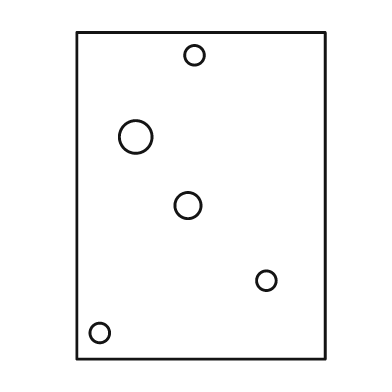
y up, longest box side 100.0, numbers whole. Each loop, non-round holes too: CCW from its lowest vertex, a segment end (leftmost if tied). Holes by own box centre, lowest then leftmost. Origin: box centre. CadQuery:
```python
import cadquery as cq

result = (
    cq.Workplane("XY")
    .moveTo(-38.0, -50.0)
    .lineTo(38.0, -50.0)
    .lineTo(38.0, 50.0)
    .lineTo(-38.0, 50.0)
    .close()
    .moveTo(-31.0, -42.0)
    .circle(3.0)
    .moveTo(20.0, -26.0)
    .circle(3.0)
    .moveTo(-4.0, -3.0)
    .circle(4.0)
    .moveTo(-20.0, 18.0)
    .circle(5.0)
    .moveTo(-2.0, 43.0)
    .circle(3.0)
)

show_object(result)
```